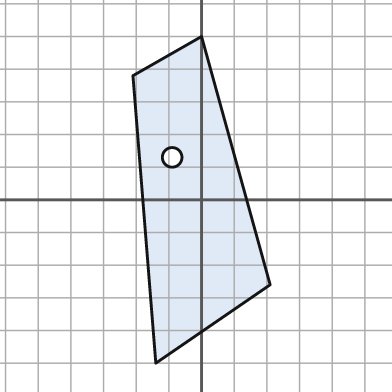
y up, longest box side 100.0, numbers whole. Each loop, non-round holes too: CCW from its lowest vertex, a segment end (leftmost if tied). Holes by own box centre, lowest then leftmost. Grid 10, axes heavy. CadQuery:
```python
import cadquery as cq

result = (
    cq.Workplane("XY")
    .moveTo(-14.0, -50.0)
    .lineTo(21.0, -26.0)
    .lineTo(0.0, 50.0)
    .lineTo(-21.0, 38.0)
    .close()
    .moveTo(-9.0, 13.0)
    .circle(3.0)
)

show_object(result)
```